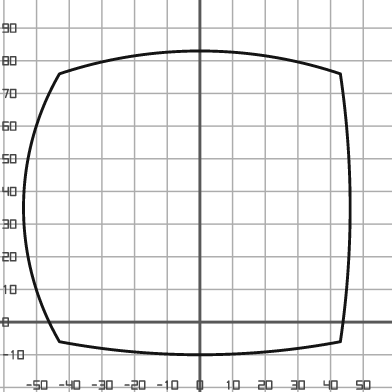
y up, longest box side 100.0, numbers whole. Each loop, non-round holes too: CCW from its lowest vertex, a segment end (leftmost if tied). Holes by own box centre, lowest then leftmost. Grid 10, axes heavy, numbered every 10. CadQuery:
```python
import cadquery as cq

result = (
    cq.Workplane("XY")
    .moveTo(-43.0, -6.0)
    .threePointArc((0.0, -10.0), (43.0, -6.0))
    .threePointArc((46.0, 35.0), (43.0, 76.0))
    .threePointArc((0.0, 83.0), (-43.0, 76.0))
    .threePointArc((-54.0, 35.0), (-43.0, -6.0))
    .close()
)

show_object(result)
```